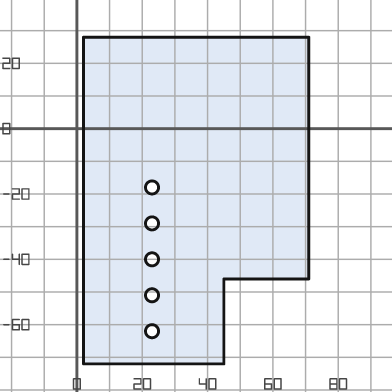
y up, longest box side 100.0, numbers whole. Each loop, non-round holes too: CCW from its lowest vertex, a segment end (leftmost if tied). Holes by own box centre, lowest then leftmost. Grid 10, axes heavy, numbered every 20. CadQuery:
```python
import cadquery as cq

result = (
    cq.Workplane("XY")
    .moveTo(2.0, -72.0)
    .lineTo(45.0, -72.0)
    .lineTo(45.0, -46.0)
    .lineTo(71.0, -46.0)
    .lineTo(71.0, 28.0)
    .lineTo(2.0, 28.0)
    .close()
    .moveTo(23.0, -62.0)
    .circle(2.0)
    .moveTo(23.0, -51.0)
    .circle(2.0)
    .moveTo(23.0, -40.0)
    .circle(2.0)
    .moveTo(23.0, -29.0)
    .circle(2.0)
    .moveTo(23.0, -18.0)
    .circle(2.0)
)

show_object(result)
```